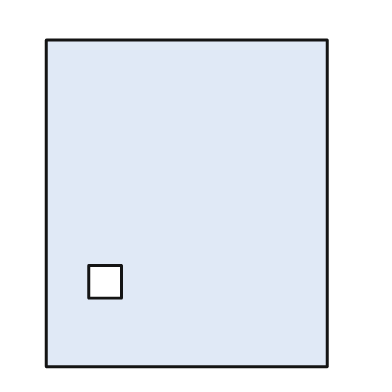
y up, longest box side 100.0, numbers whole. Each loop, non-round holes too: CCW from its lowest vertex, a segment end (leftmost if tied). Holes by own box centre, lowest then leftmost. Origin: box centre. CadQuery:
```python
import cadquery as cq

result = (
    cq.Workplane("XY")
    .moveTo(-43.0, -50.0)
    .lineTo(43.0, -50.0)
    .lineTo(43.0, 50.0)
    .lineTo(-43.0, 50.0)
    .close()
    .moveTo(-30.0, -29.0)
    .lineTo(-20.0, -29.0)
    .lineTo(-20.0, -19.0)
    .lineTo(-30.0, -19.0)
    .close()
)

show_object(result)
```